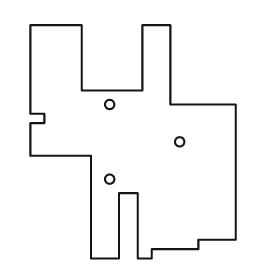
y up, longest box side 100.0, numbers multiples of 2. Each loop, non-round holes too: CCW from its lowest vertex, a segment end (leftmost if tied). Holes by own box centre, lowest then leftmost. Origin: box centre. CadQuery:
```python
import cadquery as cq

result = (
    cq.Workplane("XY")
    .moveTo(-18.0, -50.0)
    .lineTo(-6.0, -50.0)
    .lineTo(-6.0, -22.0)
    .lineTo(2.0, -22.0)
    .lineTo(2.0, -50.0)
    .lineTo(8.0, -50.0)
    .lineTo(8.0, -46.0)
    .lineTo(28.0, -46.0)
    .lineTo(28.0, -42.0)
    .lineTo(44.0, -42.0)
    .lineTo(44.0, 16.0)
    .lineTo(16.0, 16.0)
    .lineTo(16.0, 50.0)
    .lineTo(4.0, 50.0)
    .lineTo(4.0, 22.0)
    .lineTo(-22.0, 22.0)
    .lineTo(-22.0, 50.0)
    .lineTo(-44.0, 50.0)
    .lineTo(-44.0, 12.0)
    .lineTo(-38.0, 12.0)
    .lineTo(-38.0, 8.0)
    .lineTo(-44.0, 8.0)
    .lineTo(-44.0, -6.0)
    .lineTo(-18.0, -6.0)
    .close()
    .moveTo(-10.0, -16.0)
    .circle(2.0)
    .moveTo(20.0, 0.0)
    .circle(2.0)
    .moveTo(-10.0, 16.0)
    .circle(2.0)
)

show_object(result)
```